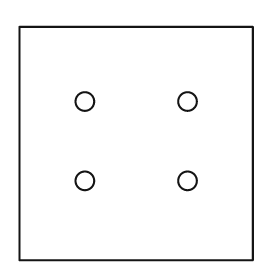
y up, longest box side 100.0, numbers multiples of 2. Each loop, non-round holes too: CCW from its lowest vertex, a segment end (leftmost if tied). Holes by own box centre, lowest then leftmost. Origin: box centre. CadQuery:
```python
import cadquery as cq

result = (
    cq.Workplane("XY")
    .moveTo(-50.0, -50.0)
    .lineTo(50.0, -50.0)
    .lineTo(50.0, 50.0)
    .lineTo(-50.0, 50.0)
    .close()
    .moveTo(-22.0, -16.0)
    .circle(4.0)
    .moveTo(22.0, -16.0)
    .circle(4.0)
    .moveTo(-22.0, 18.0)
    .circle(4.0)
    .moveTo(22.0, 18.0)
    .circle(4.0)
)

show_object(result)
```